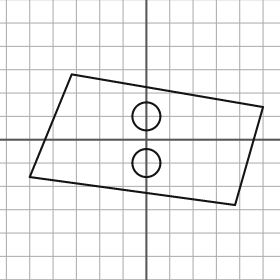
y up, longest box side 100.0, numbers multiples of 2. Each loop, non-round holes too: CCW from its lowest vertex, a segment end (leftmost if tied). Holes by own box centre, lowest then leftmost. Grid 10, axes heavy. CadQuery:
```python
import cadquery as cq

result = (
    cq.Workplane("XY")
    .moveTo(38.0, -28.0)
    .lineTo(50.0, 14.0)
    .lineTo(-32.0, 28.0)
    .lineTo(-50.0, -16.0)
    .close()
    .moveTo(0.0, -10.0)
    .circle(6.0)
    .moveTo(0.0, 10.0)
    .circle(6.0)
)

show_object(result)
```